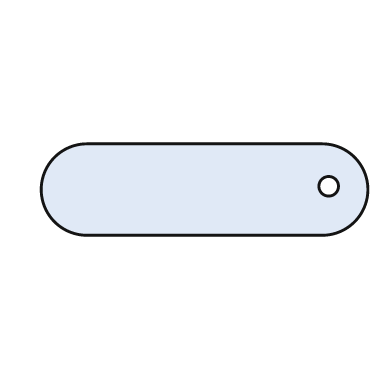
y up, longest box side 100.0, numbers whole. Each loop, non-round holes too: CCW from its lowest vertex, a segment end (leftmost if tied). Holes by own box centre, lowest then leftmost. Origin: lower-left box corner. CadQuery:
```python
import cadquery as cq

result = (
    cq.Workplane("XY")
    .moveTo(14.0, 0.0)
    .lineTo(86.0, 0.0)
    .threePointArc((100.0, 14.0), (86.0, 28.0))
    .lineTo(14.0, 28.0)
    .threePointArc((0.0, 14.0), (14.0, 0.0))
    .close()
    .moveTo(88.0, 15.0)
    .circle(3.0)
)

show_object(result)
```